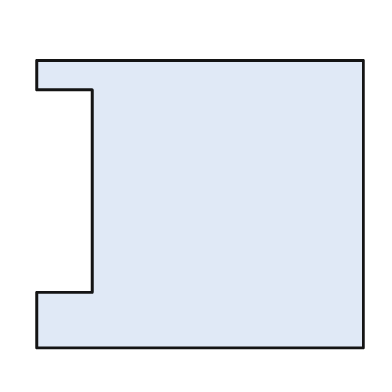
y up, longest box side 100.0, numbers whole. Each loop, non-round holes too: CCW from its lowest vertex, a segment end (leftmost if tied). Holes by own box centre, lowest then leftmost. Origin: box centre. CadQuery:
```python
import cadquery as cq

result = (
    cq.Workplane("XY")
    .moveTo(-50.0, -44.0)
    .lineTo(50.0, -44.0)
    .lineTo(50.0, 44.0)
    .lineTo(-50.0, 44.0)
    .lineTo(-50.0, 35.0)
    .lineTo(-33.0, 35.0)
    .lineTo(-33.0, -27.0)
    .lineTo(-50.0, -27.0)
    .close()
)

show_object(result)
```